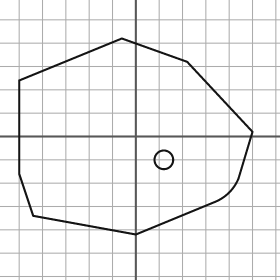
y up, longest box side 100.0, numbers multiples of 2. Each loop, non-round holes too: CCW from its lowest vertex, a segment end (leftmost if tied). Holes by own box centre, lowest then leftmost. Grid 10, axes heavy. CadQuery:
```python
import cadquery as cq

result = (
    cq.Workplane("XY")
    .moveTo(0.0, -42.0)
    .lineTo(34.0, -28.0)
    .threePointArc((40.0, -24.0), (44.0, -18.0))
    .lineTo(50.0, 2.0)
    .lineTo(22.0, 32.0)
    .lineTo(-6.0, 42.0)
    .lineTo(-50.0, 24.0)
    .lineTo(-50.0, -16.0)
    .lineTo(-44.0, -34.0)
    .close()
    .moveTo(12.0, -10.0)
    .circle(4.0)
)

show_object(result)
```